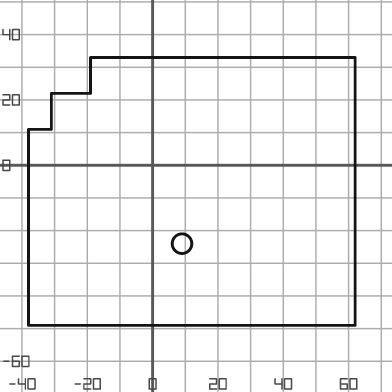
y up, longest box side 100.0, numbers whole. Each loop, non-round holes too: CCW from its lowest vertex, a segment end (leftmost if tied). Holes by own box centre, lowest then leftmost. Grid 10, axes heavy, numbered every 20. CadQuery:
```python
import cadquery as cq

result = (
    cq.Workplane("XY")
    .moveTo(-38.0, -49.0)
    .lineTo(62.0, -49.0)
    .lineTo(62.0, 33.0)
    .lineTo(-19.0, 33.0)
    .lineTo(-19.0, 22.0)
    .lineTo(-31.0, 22.0)
    .lineTo(-31.0, 11.0)
    .lineTo(-38.0, 11.0)
    .close()
    .moveTo(9.0, -24.0)
    .circle(3.0)
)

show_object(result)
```